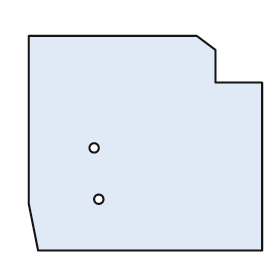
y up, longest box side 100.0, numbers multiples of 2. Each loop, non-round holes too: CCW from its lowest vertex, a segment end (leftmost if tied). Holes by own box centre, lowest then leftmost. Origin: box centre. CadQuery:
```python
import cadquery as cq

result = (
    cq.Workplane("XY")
    .moveTo(-46.0, -46.0)
    .lineTo(50.0, -46.0)
    .lineTo(50.0, 26.0)
    .lineTo(30.0, 26.0)
    .lineTo(30.0, 40.0)
    .lineTo(22.0, 46.0)
    .lineTo(-50.0, 46.0)
    .lineTo(-50.0, -26.0)
    .close()
    .moveTo(-20.0, -24.0)
    .circle(2.0)
    .moveTo(-22.0, -2.0)
    .circle(2.0)
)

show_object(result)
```